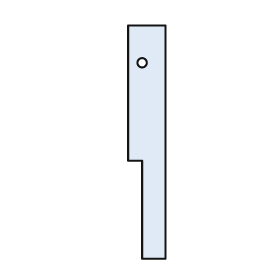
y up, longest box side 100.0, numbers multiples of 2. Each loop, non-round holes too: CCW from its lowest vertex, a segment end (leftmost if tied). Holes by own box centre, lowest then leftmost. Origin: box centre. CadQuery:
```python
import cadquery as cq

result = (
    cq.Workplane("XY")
    .moveTo(-2.0, -50.0)
    .lineTo(8.0, -50.0)
    .lineTo(8.0, 50.0)
    .lineTo(-8.0, 50.0)
    .lineTo(-8.0, -8.0)
    .lineTo(-2.0, -8.0)
    .close()
    .moveTo(-2.0, 34.0)
    .circle(2.0)
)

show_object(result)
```